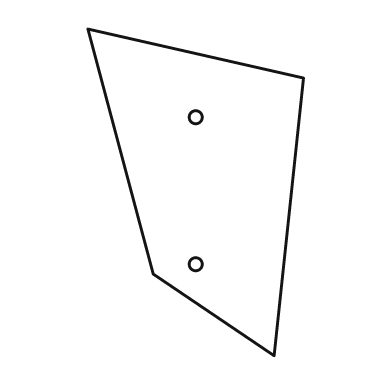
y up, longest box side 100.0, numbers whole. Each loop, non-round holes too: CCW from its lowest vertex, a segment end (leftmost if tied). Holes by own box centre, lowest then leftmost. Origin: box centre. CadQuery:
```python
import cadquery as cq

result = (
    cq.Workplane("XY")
    .moveTo(24.0, -50.0)
    .lineTo(33.0, 35.0)
    .lineTo(-33.0, 50.0)
    .lineTo(-13.0, -25.0)
    .close()
    .moveTo(0.0, -22.0)
    .circle(2.0)
    .moveTo(0.0, 23.0)
    .circle(2.0)
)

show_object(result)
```